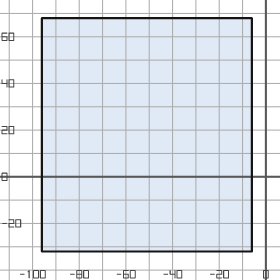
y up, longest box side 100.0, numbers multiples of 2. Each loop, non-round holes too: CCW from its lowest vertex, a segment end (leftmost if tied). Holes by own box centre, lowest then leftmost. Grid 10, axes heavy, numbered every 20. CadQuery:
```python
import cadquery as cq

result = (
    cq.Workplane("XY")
    .moveTo(-96.0, -32.0)
    .lineTo(-6.0, -32.0)
    .lineTo(-6.0, 68.0)
    .lineTo(-96.0, 68.0)
    .close()
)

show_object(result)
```